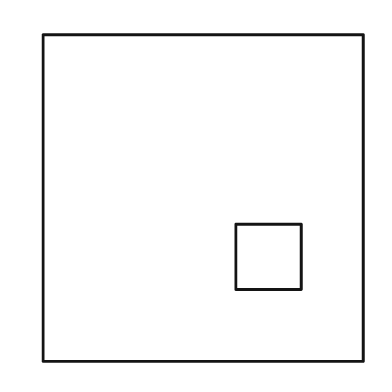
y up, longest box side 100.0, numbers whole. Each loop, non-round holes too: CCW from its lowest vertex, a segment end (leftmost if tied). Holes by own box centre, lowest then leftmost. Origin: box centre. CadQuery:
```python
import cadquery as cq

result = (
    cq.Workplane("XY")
    .moveTo(-49.0, -50.0)
    .lineTo(49.0, -50.0)
    .lineTo(49.0, 50.0)
    .lineTo(-49.0, 50.0)
    .close()
    .moveTo(10.0, -28.0)
    .lineTo(30.0, -28.0)
    .lineTo(30.0, -8.0)
    .lineTo(10.0, -8.0)
    .close()
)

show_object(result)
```